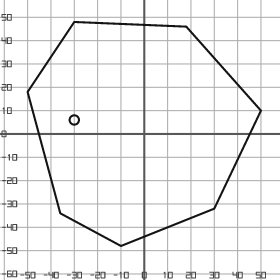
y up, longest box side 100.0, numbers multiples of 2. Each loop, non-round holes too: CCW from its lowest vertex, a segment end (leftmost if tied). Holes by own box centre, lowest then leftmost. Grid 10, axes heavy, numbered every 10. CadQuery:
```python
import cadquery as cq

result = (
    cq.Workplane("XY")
    .moveTo(-10.0, -48.0)
    .lineTo(30.0, -32.0)
    .lineTo(50.0, 10.0)
    .lineTo(18.0, 46.0)
    .lineTo(-30.0, 48.0)
    .lineTo(-50.0, 18.0)
    .lineTo(-36.0, -34.0)
    .close()
    .moveTo(-30.0, 6.0)
    .circle(2.0)
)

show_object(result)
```